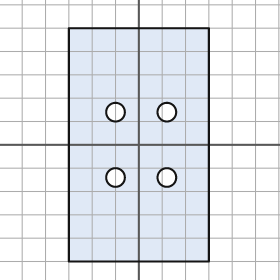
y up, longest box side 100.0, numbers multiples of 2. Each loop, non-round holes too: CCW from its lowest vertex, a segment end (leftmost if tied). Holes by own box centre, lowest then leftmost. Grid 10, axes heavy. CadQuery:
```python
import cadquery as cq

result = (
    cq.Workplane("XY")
    .moveTo(-30.0, -50.0)
    .lineTo(30.0, -50.0)
    .lineTo(30.0, 50.0)
    .lineTo(-30.0, 50.0)
    .close()
    .moveTo(-10.0, -14.0)
    .circle(4.0)
    .moveTo(12.0, -14.0)
    .circle(4.0)
    .moveTo(-10.0, 14.0)
    .circle(4.0)
    .moveTo(12.0, 14.0)
    .circle(4.0)
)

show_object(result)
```